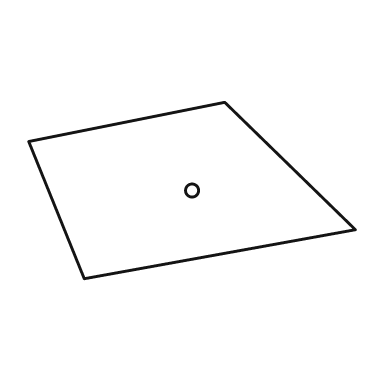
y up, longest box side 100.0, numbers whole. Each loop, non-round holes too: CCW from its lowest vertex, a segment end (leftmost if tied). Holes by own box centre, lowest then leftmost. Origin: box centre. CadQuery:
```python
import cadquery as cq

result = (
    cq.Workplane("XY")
    .moveTo(-33.0, -27.0)
    .lineTo(50.0, -12.0)
    .lineTo(10.0, 27.0)
    .lineTo(-50.0, 15.0)
    .close()
    .moveTo(0.0, 0.0)
    .circle(2.0)
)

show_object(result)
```